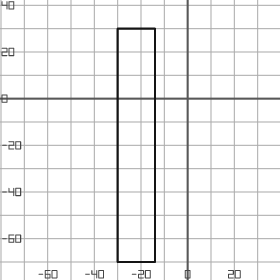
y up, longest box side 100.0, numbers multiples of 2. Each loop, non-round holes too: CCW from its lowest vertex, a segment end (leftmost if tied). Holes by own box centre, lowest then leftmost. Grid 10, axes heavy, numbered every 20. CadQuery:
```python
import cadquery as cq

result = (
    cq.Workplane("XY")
    .moveTo(-30.0, -70.0)
    .lineTo(-14.0, -70.0)
    .lineTo(-14.0, 30.0)
    .lineTo(-30.0, 30.0)
    .close()
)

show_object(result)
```